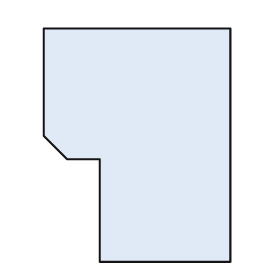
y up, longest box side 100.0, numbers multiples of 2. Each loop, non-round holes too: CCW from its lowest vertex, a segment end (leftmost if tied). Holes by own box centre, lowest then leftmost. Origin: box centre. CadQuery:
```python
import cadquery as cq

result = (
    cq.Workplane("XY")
    .moveTo(-16.0, -50.0)
    .lineTo(40.0, -50.0)
    .lineTo(40.0, 50.0)
    .lineTo(-40.0, 50.0)
    .lineTo(-40.0, 4.0)
    .lineTo(-30.0, -6.0)
    .lineTo(-16.0, -6.0)
    .close()
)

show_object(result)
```